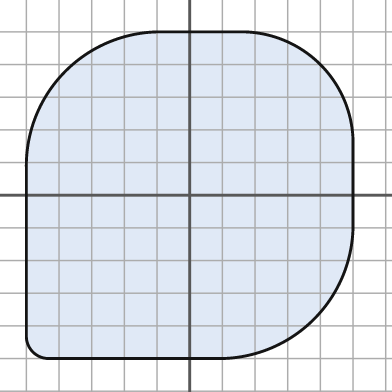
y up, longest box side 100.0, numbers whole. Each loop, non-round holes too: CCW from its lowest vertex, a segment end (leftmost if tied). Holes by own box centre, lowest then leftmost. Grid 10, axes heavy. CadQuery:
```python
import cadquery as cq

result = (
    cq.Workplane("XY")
    .moveTo(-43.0, -50.0)
    .lineTo(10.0, -50.0)
    .threePointArc((38.0, -38.0), (50.0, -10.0))
    .lineTo(50.0, 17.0)
    .threePointArc((40.0, 40.0), (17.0, 50.0))
    .lineTo(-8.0, 50.0)
    .threePointArc((-38.0, 38.0), (-50.0, 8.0))
    .lineTo(-50.0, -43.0)
    .threePointArc((-48.0, -48.0), (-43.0, -50.0))
    .close()
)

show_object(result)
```